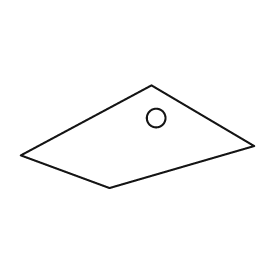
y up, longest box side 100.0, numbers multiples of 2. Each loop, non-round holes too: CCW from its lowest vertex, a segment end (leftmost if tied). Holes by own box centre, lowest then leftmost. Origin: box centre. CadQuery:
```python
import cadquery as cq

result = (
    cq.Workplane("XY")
    .moveTo(-12.0, -22.0)
    .lineTo(50.0, -4.0)
    .lineTo(6.0, 22.0)
    .lineTo(-50.0, -8.0)
    .close()
    .moveTo(8.0, 8.0)
    .circle(4.0)
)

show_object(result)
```